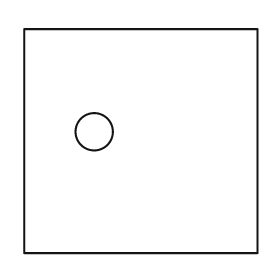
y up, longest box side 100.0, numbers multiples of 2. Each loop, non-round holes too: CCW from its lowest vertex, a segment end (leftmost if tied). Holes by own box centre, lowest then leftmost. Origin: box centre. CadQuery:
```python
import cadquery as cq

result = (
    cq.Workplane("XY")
    .moveTo(-50.0, -48.0)
    .lineTo(50.0, -48.0)
    .lineTo(50.0, 48.0)
    .lineTo(-50.0, 48.0)
    .close()
    .moveTo(-20.0, 4.0)
    .circle(8.0)
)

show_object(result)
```